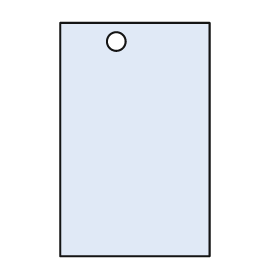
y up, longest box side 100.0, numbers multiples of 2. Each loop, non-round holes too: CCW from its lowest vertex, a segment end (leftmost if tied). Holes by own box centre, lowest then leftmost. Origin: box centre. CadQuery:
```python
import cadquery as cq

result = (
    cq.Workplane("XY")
    .moveTo(-32.0, -50.0)
    .lineTo(32.0, -50.0)
    .lineTo(32.0, 50.0)
    .lineTo(-32.0, 50.0)
    .close()
    .moveTo(-8.0, 42.0)
    .circle(4.0)
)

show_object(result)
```